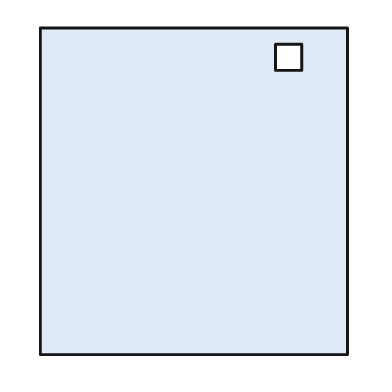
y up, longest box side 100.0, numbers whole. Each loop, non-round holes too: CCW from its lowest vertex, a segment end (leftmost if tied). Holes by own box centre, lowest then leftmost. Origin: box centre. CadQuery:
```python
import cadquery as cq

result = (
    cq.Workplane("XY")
    .moveTo(-47.0, -50.0)
    .lineTo(47.0, -50.0)
    .lineTo(47.0, 50.0)
    .lineTo(-47.0, 50.0)
    .close()
    .moveTo(25.0, 37.0)
    .lineTo(33.0, 37.0)
    .lineTo(33.0, 45.0)
    .lineTo(25.0, 45.0)
    .close()
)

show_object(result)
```